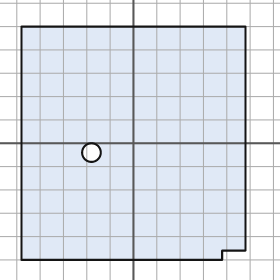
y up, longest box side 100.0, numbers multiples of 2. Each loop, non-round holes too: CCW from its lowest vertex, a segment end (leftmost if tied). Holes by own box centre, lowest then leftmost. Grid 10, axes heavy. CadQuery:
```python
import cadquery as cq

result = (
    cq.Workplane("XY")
    .moveTo(-48.0, -50.0)
    .lineTo(38.0, -50.0)
    .lineTo(38.0, -46.0)
    .lineTo(48.0, -46.0)
    .lineTo(48.0, 50.0)
    .lineTo(-48.0, 50.0)
    .close()
    .moveTo(-18.0, -4.0)
    .circle(4.0)
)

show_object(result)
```